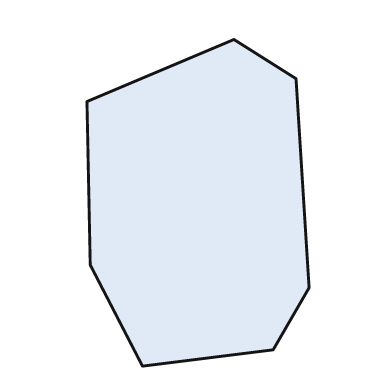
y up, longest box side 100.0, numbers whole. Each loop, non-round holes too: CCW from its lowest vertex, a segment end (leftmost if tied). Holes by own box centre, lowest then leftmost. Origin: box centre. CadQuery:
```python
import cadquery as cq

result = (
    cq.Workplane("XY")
    .moveTo(-17.0, -50.0)
    .lineTo(23.0, -45.0)
    .lineTo(34.0, -26.0)
    .lineTo(30.0, 38.0)
    .lineTo(11.0, 50.0)
    .lineTo(-34.0, 31.0)
    .lineTo(-33.0, -19.0)
    .close()
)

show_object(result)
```